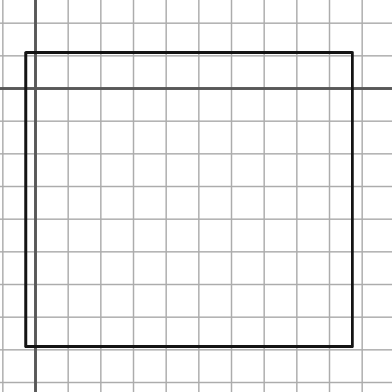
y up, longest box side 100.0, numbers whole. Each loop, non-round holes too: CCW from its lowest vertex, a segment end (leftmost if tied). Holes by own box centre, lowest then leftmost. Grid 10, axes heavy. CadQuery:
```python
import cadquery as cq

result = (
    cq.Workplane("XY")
    .moveTo(-3.0, -79.0)
    .lineTo(97.0, -79.0)
    .lineTo(97.0, 11.0)
    .lineTo(-3.0, 11.0)
    .close()
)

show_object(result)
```